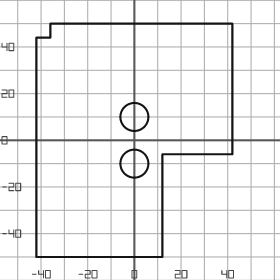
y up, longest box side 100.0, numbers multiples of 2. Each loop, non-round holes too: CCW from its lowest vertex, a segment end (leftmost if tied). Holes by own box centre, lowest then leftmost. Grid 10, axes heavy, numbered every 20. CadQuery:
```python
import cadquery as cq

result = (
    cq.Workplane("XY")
    .moveTo(-42.0, -50.0)
    .lineTo(12.0, -50.0)
    .lineTo(12.0, -6.0)
    .lineTo(42.0, -6.0)
    .lineTo(42.0, 50.0)
    .lineTo(-36.0, 50.0)
    .lineTo(-36.0, 44.0)
    .lineTo(-42.0, 44.0)
    .close()
    .moveTo(0.0, -10.0)
    .circle(6.0)
    .moveTo(0.0, 10.0)
    .circle(6.0)
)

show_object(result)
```